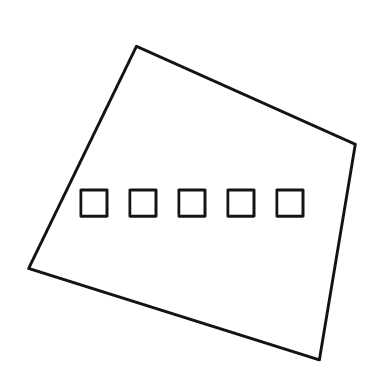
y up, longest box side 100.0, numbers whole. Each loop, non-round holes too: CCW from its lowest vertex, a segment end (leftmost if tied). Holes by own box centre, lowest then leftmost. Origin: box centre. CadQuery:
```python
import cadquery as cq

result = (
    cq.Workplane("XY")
    .moveTo(39.0, -48.0)
    .lineTo(50.0, 18.0)
    .lineTo(-17.0, 48.0)
    .lineTo(-50.0, -20.0)
    .close()
    .moveTo(-34.0, -4.0)
    .lineTo(-26.0, -4.0)
    .lineTo(-26.0, 4.0)
    .lineTo(-34.0, 4.0)
    .close()
    .moveTo(-19.0, -4.0)
    .lineTo(-11.0, -4.0)
    .lineTo(-11.0, 4.0)
    .lineTo(-19.0, 4.0)
    .close()
    .moveTo(-4.0, -4.0)
    .lineTo(4.0, -4.0)
    .lineTo(4.0, 4.0)
    .lineTo(-4.0, 4.0)
    .close()
    .moveTo(11.0, -4.0)
    .lineTo(19.0, -4.0)
    .lineTo(19.0, 4.0)
    .lineTo(11.0, 4.0)
    .close()
    .moveTo(26.0, -4.0)
    .lineTo(34.0, -4.0)
    .lineTo(34.0, 4.0)
    .lineTo(26.0, 4.0)
    .close()
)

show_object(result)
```